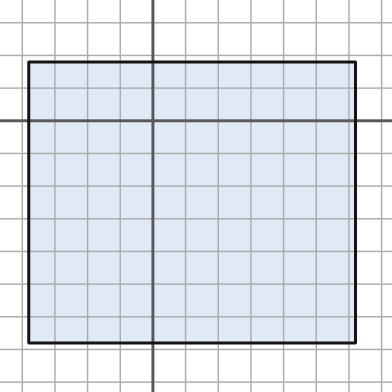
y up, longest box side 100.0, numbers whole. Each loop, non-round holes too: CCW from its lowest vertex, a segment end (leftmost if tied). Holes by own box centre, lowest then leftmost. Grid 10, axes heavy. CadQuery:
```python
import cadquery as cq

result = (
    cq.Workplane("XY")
    .moveTo(-38.0, -68.0)
    .lineTo(62.0, -68.0)
    .lineTo(62.0, 18.0)
    .lineTo(-38.0, 18.0)
    .close()
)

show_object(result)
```